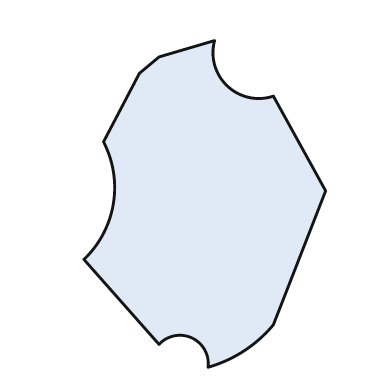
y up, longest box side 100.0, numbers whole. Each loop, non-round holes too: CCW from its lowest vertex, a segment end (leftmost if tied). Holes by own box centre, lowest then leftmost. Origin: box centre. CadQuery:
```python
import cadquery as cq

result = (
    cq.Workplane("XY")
    .moveTo(1.0, -50.0)
    .threePointArc((12.0, -45.0), (21.0, -37.0))
    .lineTo(37.0, 4.0)
    .lineTo(21.0, 33.0)
    .threePointArc((7.0, 36.0), (3.0, 50.0))
    .lineTo(-14.0, 45.0)
    .lineTo(-20.0, 40.0)
    .lineTo(-31.0, 19.0)
    .threePointArc((-28.0, 0.0), (-37.0, -17.0))
    .lineTo(-14.0, -43.0)
    .threePointArc((-4.0, -41.0), (1.0, -50.0))
    .close()
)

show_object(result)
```